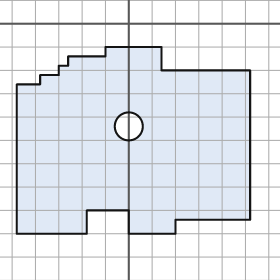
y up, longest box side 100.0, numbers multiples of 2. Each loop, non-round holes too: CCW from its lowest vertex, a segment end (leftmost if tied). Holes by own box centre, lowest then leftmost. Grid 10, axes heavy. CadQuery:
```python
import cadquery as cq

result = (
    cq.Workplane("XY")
    .moveTo(-48.0, -90.0)
    .lineTo(-18.0, -90.0)
    .lineTo(-18.0, -80.0)
    .lineTo(0.0, -80.0)
    .lineTo(0.0, -90.0)
    .lineTo(20.0, -90.0)
    .lineTo(20.0, -84.0)
    .lineTo(52.0, -84.0)
    .lineTo(52.0, -20.0)
    .lineTo(14.0, -20.0)
    .lineTo(14.0, -10.0)
    .lineTo(-10.0, -10.0)
    .lineTo(-10.0, -14.0)
    .lineTo(-26.0, -14.0)
    .lineTo(-26.0, -18.0)
    .lineTo(-30.0, -18.0)
    .lineTo(-30.0, -22.0)
    .lineTo(-38.0, -22.0)
    .lineTo(-38.0, -26.0)
    .lineTo(-48.0, -26.0)
    .close()
    .moveTo(0.0, -44.0)
    .circle(6.0)
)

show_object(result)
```